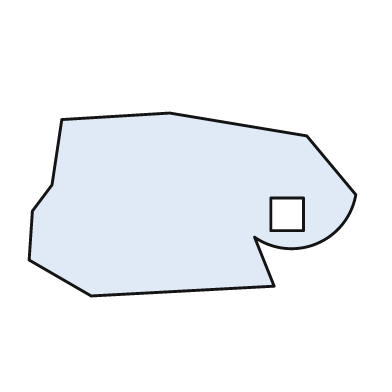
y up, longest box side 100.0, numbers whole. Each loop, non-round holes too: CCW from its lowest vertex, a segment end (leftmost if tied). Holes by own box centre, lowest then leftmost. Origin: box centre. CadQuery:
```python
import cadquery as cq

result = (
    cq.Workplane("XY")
    .moveTo(-31.0, -28.0)
    .lineTo(25.0, -25.0)
    .lineTo(19.0, -10.0)
    .threePointArc((38.0, -12.0), (50.0, 3.0))
    .lineTo(35.0, 21.0)
    .lineTo(-7.0, 28.0)
    .lineTo(-40.0, 26.0)
    .lineTo(-43.0, 6.0)
    .lineTo(-49.0, -2.0)
    .lineTo(-50.0, -17.0)
    .close()
    .moveTo(24.0, -8.0)
    .lineTo(34.0, -8.0)
    .lineTo(34.0, 2.0)
    .lineTo(24.0, 2.0)
    .close()
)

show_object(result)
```